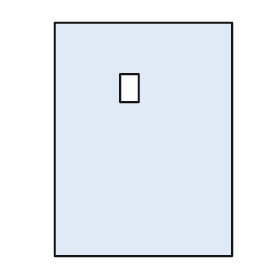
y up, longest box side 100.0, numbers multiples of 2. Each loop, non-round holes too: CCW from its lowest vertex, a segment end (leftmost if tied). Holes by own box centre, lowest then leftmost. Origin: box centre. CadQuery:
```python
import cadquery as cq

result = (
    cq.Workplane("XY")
    .moveTo(-38.0, -50.0)
    .lineTo(38.0, -50.0)
    .lineTo(38.0, 50.0)
    .lineTo(-38.0, 50.0)
    .close()
    .moveTo(-10.0, 16.0)
    .lineTo(-2.0, 16.0)
    .lineTo(-2.0, 28.0)
    .lineTo(-10.0, 28.0)
    .close()
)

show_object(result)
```